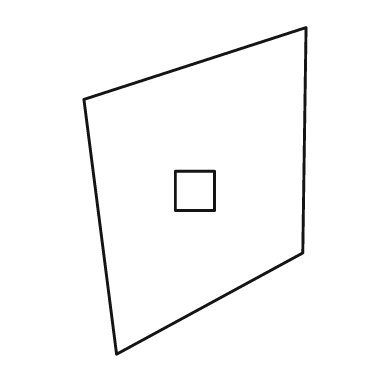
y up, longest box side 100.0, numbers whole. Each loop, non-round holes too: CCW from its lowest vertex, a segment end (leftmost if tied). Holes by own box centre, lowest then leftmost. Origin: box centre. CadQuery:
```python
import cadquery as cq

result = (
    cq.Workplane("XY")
    .moveTo(-24.0, -50.0)
    .lineTo(33.0, -19.0)
    .lineTo(34.0, 50.0)
    .lineTo(-34.0, 28.0)
    .close()
    .moveTo(-6.0, -6.0)
    .lineTo(6.0, -6.0)
    .lineTo(6.0, 6.0)
    .lineTo(-6.0, 6.0)
    .close()
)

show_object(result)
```